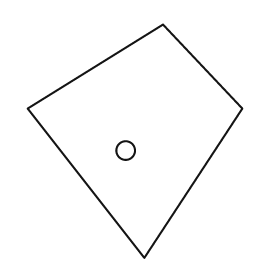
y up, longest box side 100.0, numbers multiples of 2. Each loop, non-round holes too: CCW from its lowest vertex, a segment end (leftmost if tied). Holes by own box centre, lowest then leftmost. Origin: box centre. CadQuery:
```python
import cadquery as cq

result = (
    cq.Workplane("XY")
    .moveTo(4.0, -50.0)
    .lineTo(46.0, 14.0)
    .lineTo(12.0, 50.0)
    .lineTo(-46.0, 14.0)
    .close()
    .moveTo(-4.0, -4.0)
    .circle(4.0)
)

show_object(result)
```